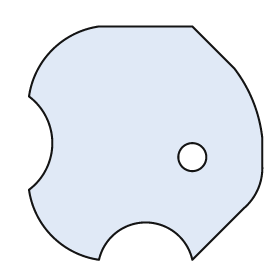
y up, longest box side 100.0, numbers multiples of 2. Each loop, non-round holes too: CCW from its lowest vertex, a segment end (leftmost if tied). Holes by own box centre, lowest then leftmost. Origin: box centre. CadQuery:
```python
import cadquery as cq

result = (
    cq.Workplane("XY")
    .moveTo(-20.0, -50.0)
    .threePointArc((0.0, -34.0), (20.0, -50.0))
    .lineTo(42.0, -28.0)
    .threePointArc((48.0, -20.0), (50.0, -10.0))
    .lineTo(50.0, 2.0)
    .threePointArc((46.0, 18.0), (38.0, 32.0))
    .lineTo(20.0, 50.0)
    .lineTo(-20.0, 50.0)
    .threePointArc((-40.0, 40.0), (-50.0, 20.0))
    .threePointArc((-40.0, 0.0), (-50.0, -20.0))
    .threePointArc((-40.0, -40.0), (-20.0, -50.0))
    .close()
    .moveTo(20.0, -6.0)
    .circle(6.0)
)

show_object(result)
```